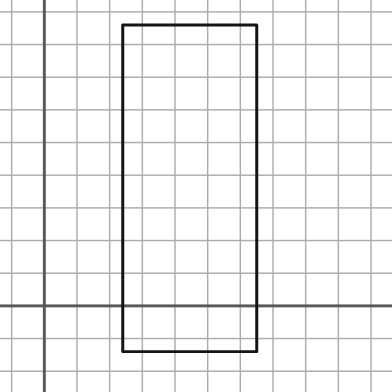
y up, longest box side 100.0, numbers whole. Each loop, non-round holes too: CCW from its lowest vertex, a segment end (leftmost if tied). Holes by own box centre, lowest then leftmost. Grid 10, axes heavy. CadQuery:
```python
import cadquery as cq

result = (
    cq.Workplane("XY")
    .moveTo(24.0, -14.0)
    .lineTo(65.0, -14.0)
    .lineTo(65.0, 86.0)
    .lineTo(24.0, 86.0)
    .close()
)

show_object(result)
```